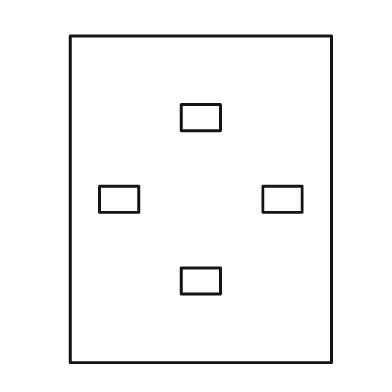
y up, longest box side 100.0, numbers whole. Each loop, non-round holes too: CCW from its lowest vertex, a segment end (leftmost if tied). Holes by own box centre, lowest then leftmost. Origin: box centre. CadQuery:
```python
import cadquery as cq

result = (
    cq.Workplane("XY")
    .moveTo(-40.0, -50.0)
    .lineTo(40.0, -50.0)
    .lineTo(40.0, 50.0)
    .lineTo(-40.0, 50.0)
    .close()
    .moveTo(-6.0, -29.0)
    .lineTo(6.0, -29.0)
    .lineTo(6.0, -21.0)
    .lineTo(-6.0, -21.0)
    .close()
    .moveTo(-31.0, -4.0)
    .lineTo(-19.0, -4.0)
    .lineTo(-19.0, 4.0)
    .lineTo(-31.0, 4.0)
    .close()
    .moveTo(19.0, -4.0)
    .lineTo(31.0, -4.0)
    .lineTo(31.0, 4.0)
    .lineTo(19.0, 4.0)
    .close()
    .moveTo(-6.0, 21.0)
    .lineTo(6.0, 21.0)
    .lineTo(6.0, 29.0)
    .lineTo(-6.0, 29.0)
    .close()
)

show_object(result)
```